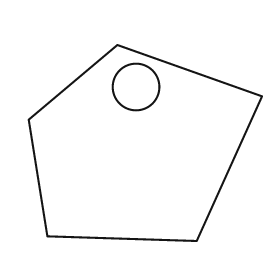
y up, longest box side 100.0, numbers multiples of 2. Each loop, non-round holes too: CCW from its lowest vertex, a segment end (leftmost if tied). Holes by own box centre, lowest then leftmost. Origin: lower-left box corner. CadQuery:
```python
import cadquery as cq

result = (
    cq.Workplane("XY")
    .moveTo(72.0, 0.0)
    .lineTo(100.0, 62.0)
    .lineTo(38.0, 84.0)
    .lineTo(0.0, 52.0)
    .lineTo(8.0, 2.0)
    .close()
    .moveTo(46.0, 66.0)
    .circle(10.0)
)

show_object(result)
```